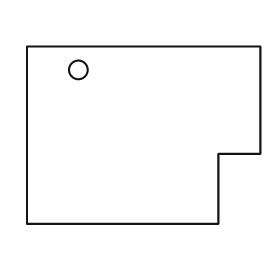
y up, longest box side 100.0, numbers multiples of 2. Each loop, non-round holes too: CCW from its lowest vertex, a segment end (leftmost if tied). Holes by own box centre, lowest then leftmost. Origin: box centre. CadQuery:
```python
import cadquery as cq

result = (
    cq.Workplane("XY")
    .moveTo(-50.0, -38.0)
    .lineTo(32.0, -38.0)
    .lineTo(32.0, -8.0)
    .lineTo(50.0, -8.0)
    .lineTo(50.0, 38.0)
    .lineTo(-50.0, 38.0)
    .close()
    .moveTo(-28.0, 28.0)
    .circle(4.0)
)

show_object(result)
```